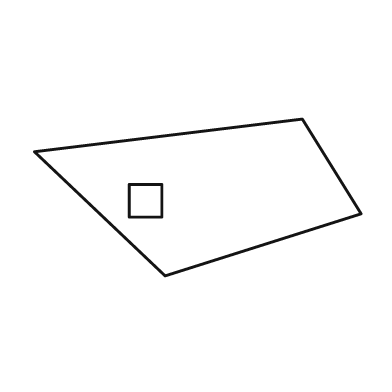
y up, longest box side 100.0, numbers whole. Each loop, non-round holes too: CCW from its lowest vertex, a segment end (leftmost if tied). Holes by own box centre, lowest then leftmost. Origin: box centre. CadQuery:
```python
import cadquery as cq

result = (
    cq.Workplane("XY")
    .moveTo(-10.0, -24.0)
    .lineTo(50.0, -5.0)
    .lineTo(32.0, 24.0)
    .lineTo(-50.0, 14.0)
    .close()
    .moveTo(-21.0, -6.0)
    .lineTo(-11.0, -6.0)
    .lineTo(-11.0, 4.0)
    .lineTo(-21.0, 4.0)
    .close()
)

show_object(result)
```